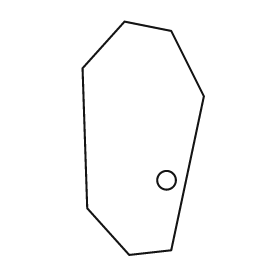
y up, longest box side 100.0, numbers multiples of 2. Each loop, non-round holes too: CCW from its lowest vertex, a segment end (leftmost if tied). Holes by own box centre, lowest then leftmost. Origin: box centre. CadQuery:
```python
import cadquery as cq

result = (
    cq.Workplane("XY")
    .moveTo(-6.0, -50.0)
    .lineTo(12.0, -48.0)
    .lineTo(26.0, 18.0)
    .lineTo(12.0, 46.0)
    .lineTo(-8.0, 50.0)
    .lineTo(-26.0, 30.0)
    .lineTo(-24.0, -30.0)
    .close()
    .moveTo(10.0, -18.0)
    .circle(4.0)
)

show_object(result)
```